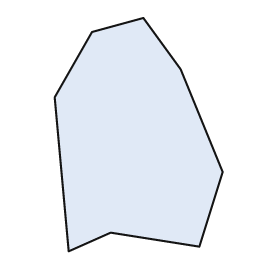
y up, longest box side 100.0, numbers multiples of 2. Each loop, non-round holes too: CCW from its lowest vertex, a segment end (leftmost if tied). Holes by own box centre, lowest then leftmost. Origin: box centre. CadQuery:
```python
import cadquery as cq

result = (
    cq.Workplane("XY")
    .moveTo(-30.0, -50.0)
    .lineTo(-12.0, -42.0)
    .lineTo(26.0, -48.0)
    .lineTo(36.0, -16.0)
    .lineTo(18.0, 28.0)
    .lineTo(2.0, 50.0)
    .lineTo(-20.0, 44.0)
    .lineTo(-36.0, 16.0)
    .close()
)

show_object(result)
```